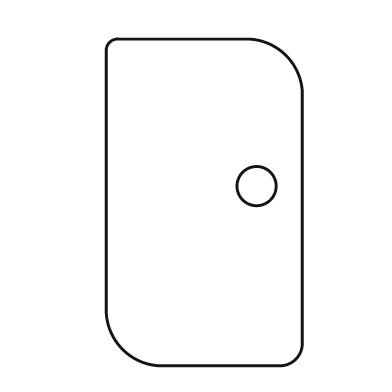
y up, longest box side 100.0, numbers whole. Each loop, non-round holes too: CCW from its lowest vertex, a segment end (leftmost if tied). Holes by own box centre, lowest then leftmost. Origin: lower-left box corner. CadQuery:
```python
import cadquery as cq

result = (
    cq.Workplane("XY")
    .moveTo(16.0, 0.0)
    .lineTo(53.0, 0.0)
    .threePointArc((58.0, 2.0), (60.0, 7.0))
    .lineTo(60.0, 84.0)
    .threePointArc((55.0, 95.0), (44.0, 100.0))
    .lineTo(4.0, 100.0)
    .threePointArc((1.0, 99.0), (0.0, 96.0))
    .lineTo(0.0, 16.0)
    .threePointArc((5.0, 5.0), (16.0, 0.0))
    .close()
    .moveTo(46.0, 55.0)
    .circle(6.0)
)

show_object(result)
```